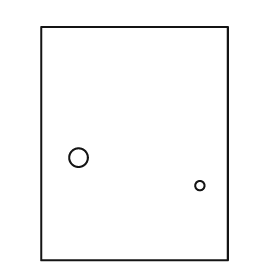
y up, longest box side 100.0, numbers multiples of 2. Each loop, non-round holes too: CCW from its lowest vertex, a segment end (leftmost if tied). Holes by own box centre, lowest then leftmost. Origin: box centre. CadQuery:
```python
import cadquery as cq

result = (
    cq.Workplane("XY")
    .moveTo(-40.0, -50.0)
    .lineTo(40.0, -50.0)
    .lineTo(40.0, 50.0)
    .lineTo(-40.0, 50.0)
    .close()
    .moveTo(28.0, -18.0)
    .circle(2.0)
    .moveTo(-24.0, -6.0)
    .circle(4.0)
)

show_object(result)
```